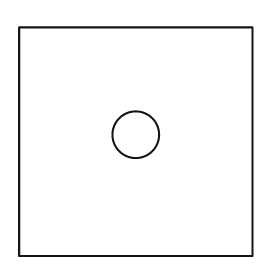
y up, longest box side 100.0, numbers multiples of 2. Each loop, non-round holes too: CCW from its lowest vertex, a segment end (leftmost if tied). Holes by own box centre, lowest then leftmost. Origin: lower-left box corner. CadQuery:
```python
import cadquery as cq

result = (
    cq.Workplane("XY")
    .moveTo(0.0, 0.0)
    .lineTo(100.0, 0.0)
    .lineTo(100.0, 98.0)
    .lineTo(0.0, 98.0)
    .close()
    .moveTo(50.0, 52.0)
    .circle(10.0)
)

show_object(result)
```